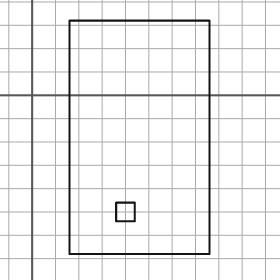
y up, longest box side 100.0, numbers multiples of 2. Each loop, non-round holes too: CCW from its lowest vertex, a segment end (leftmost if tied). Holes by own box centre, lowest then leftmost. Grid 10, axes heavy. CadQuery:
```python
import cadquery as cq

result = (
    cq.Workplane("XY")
    .moveTo(16.0, -68.0)
    .lineTo(76.0, -68.0)
    .lineTo(76.0, 32.0)
    .lineTo(16.0, 32.0)
    .close()
    .moveTo(36.0, -54.0)
    .lineTo(44.0, -54.0)
    .lineTo(44.0, -46.0)
    .lineTo(36.0, -46.0)
    .close()
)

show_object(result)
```